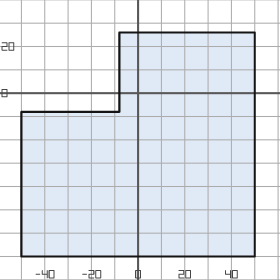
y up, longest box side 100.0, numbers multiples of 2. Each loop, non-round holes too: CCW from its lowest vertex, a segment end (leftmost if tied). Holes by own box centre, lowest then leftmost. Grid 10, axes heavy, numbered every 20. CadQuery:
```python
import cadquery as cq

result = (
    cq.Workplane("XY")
    .moveTo(-50.0, -70.0)
    .lineTo(50.0, -70.0)
    .lineTo(50.0, 26.0)
    .lineTo(-8.0, 26.0)
    .lineTo(-8.0, -8.0)
    .lineTo(-50.0, -8.0)
    .close()
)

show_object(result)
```